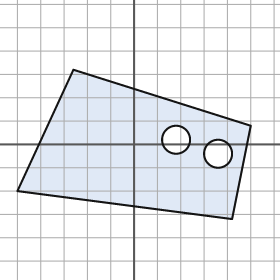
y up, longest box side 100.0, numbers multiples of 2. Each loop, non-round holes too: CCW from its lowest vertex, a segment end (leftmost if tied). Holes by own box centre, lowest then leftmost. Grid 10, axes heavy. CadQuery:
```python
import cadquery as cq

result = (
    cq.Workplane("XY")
    .moveTo(42.0, -32.0)
    .lineTo(50.0, 8.0)
    .lineTo(-26.0, 32.0)
    .lineTo(-50.0, -20.0)
    .close()
    .moveTo(36.0, -4.0)
    .circle(6.0)
    .moveTo(18.0, 2.0)
    .circle(6.0)
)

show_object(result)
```